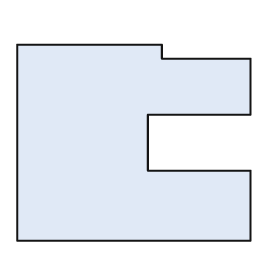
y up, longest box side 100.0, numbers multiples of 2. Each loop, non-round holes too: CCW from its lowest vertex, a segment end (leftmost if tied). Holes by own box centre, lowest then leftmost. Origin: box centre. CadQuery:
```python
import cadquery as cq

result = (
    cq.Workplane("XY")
    .moveTo(-50.0, -42.0)
    .lineTo(50.0, -42.0)
    .lineTo(50.0, -12.0)
    .lineTo(6.0, -12.0)
    .lineTo(6.0, 12.0)
    .lineTo(50.0, 12.0)
    .lineTo(50.0, 36.0)
    .lineTo(12.0, 36.0)
    .lineTo(12.0, 42.0)
    .lineTo(-50.0, 42.0)
    .close()
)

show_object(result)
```